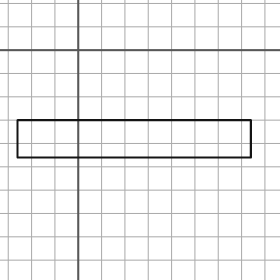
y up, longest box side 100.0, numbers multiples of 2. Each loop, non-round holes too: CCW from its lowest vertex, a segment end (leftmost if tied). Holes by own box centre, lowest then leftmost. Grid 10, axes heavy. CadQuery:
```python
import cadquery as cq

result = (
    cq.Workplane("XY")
    .moveTo(-26.0, -46.0)
    .lineTo(74.0, -46.0)
    .lineTo(74.0, -30.0)
    .lineTo(-26.0, -30.0)
    .close()
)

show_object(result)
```